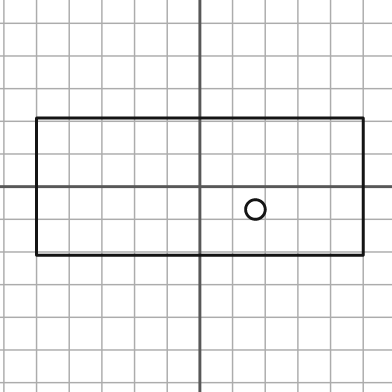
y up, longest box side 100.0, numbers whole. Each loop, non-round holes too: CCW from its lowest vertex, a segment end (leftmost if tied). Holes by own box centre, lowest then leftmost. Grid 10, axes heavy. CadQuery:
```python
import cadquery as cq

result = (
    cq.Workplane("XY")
    .moveTo(-50.0, -21.0)
    .lineTo(50.0, -21.0)
    .lineTo(50.0, 21.0)
    .lineTo(-50.0, 21.0)
    .close()
    .moveTo(17.0, -7.0)
    .circle(3.0)
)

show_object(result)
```